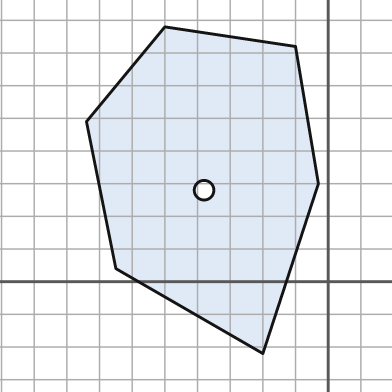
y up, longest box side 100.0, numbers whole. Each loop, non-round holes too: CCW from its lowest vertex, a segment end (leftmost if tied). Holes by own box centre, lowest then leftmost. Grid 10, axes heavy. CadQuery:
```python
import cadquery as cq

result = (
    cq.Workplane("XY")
    .moveTo(-20.0, -22.0)
    .lineTo(-3.0, 30.0)
    .lineTo(-10.0, 72.0)
    .lineTo(-50.0, 78.0)
    .lineTo(-74.0, 49.0)
    .lineTo(-65.0, 4.0)
    .close()
    .moveTo(-38.0, 28.0)
    .circle(3.0)
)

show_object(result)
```